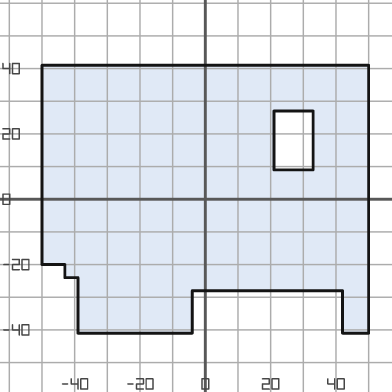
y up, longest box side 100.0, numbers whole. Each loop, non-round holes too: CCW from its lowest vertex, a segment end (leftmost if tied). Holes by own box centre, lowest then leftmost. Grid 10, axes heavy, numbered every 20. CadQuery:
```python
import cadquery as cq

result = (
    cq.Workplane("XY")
    .moveTo(-39.0, -41.0)
    .lineTo(-4.0, -41.0)
    .lineTo(-4.0, -28.0)
    .lineTo(42.0, -28.0)
    .lineTo(42.0, -41.0)
    .lineTo(50.0, -41.0)
    .lineTo(50.0, 41.0)
    .lineTo(-50.0, 41.0)
    .lineTo(-50.0, -20.0)
    .lineTo(-43.0, -20.0)
    .lineTo(-43.0, -24.0)
    .lineTo(-39.0, -24.0)
    .close()
    .moveTo(21.0, 9.0)
    .lineTo(33.0, 9.0)
    .lineTo(33.0, 27.0)
    .lineTo(21.0, 27.0)
    .close()
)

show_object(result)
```